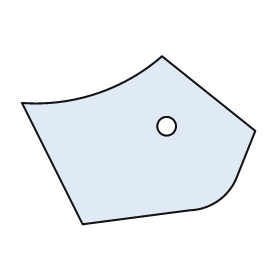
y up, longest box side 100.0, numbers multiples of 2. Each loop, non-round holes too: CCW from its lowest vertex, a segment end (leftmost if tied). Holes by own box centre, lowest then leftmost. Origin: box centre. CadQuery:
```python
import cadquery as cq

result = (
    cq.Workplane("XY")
    .moveTo(-24.0, -36.0)
    .lineTo(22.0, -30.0)
    .threePointArc((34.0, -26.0), (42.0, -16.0))
    .lineTo(50.0, 4.0)
    .lineTo(10.0, 36.0)
    .threePointArc((-18.0, 20.0), (-50.0, 16.0))
    .close()
    .moveTo(12.0, 6.0)
    .circle(4.0)
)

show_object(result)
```